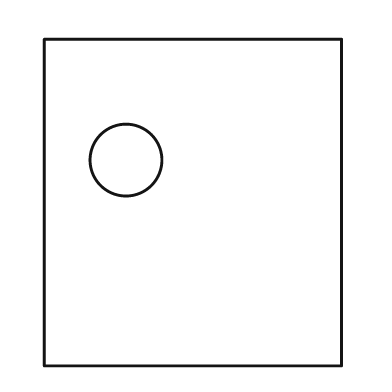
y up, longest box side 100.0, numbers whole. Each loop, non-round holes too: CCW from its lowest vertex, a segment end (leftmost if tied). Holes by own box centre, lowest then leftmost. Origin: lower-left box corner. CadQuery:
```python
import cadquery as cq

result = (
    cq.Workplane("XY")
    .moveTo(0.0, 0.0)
    .lineTo(91.0, 0.0)
    .lineTo(91.0, 100.0)
    .lineTo(0.0, 100.0)
    .close()
    .moveTo(25.0, 63.0)
    .circle(11.0)
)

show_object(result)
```